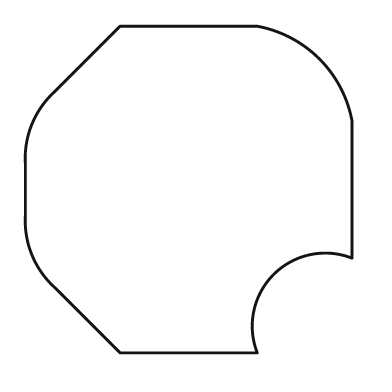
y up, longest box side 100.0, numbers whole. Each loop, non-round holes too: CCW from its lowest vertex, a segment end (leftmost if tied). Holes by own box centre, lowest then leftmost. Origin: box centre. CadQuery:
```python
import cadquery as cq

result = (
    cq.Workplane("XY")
    .moveTo(-21.0, -50.0)
    .lineTo(21.0, -50.0)
    .threePointArc((26.0, -26.0), (50.0, -21.0))
    .lineTo(50.0, 21.0)
    .threePointArc((40.0, 40.0), (21.0, 50.0))
    .lineTo(-21.0, 50.0)
    .lineTo(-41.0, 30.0)
    .threePointArc((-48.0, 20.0), (-50.0, 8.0))
    .lineTo(-50.0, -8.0)
    .threePointArc((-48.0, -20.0), (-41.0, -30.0))
    .close()
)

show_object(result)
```